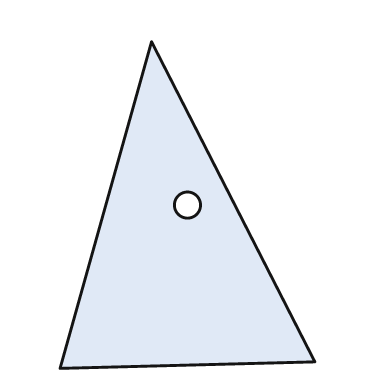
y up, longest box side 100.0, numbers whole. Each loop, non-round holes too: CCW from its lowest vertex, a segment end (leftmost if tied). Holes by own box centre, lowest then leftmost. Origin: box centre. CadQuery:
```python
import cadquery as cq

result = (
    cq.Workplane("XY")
    .moveTo(-39.0, -50.0)
    .lineTo(39.0, -48.0)
    .lineTo(-11.0, 50.0)
    .close()
    .moveTo(0.0, 0.0)
    .circle(4.0)
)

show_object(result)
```